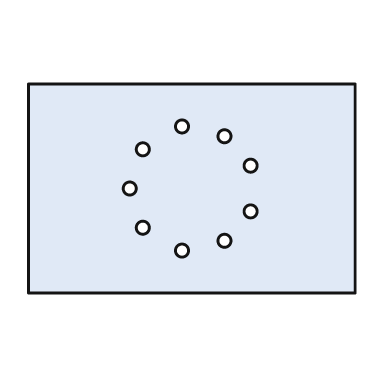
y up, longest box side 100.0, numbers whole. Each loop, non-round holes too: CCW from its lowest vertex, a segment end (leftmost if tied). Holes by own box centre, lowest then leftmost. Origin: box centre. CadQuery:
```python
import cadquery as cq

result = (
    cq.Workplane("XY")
    .moveTo(-50.0, -32.0)
    .lineTo(50.0, -32.0)
    .lineTo(50.0, 32.0)
    .lineTo(-50.0, 32.0)
    .close()
    .moveTo(-3.0, -19.0)
    .circle(2.0)
    .moveTo(10.0, -16.0)
    .circle(2.0)
    .moveTo(-15.0, -12.0)
    .circle(2.0)
    .moveTo(18.0, -7.0)
    .circle(2.0)
    .moveTo(-19.0, 0.0)
    .circle(2.0)
    .moveTo(18.0, 7.0)
    .circle(2.0)
    .moveTo(-15.0, 12.0)
    .circle(2.0)
    .moveTo(10.0, 16.0)
    .circle(2.0)
    .moveTo(-3.0, 19.0)
    .circle(2.0)
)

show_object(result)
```